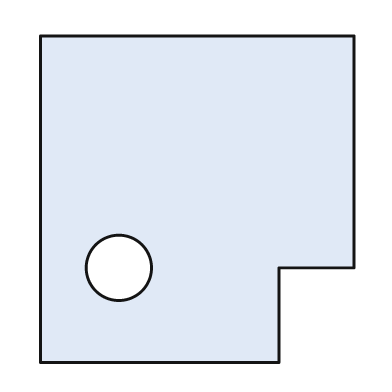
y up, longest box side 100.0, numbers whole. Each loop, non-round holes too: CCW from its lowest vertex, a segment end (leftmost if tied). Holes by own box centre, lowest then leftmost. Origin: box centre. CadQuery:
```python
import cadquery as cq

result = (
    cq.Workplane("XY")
    .moveTo(-48.0, -50.0)
    .lineTo(25.0, -50.0)
    .lineTo(25.0, -21.0)
    .lineTo(48.0, -21.0)
    .lineTo(48.0, 50.0)
    .lineTo(-48.0, 50.0)
    .close()
    .moveTo(-24.0, -21.0)
    .circle(10.0)
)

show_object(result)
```